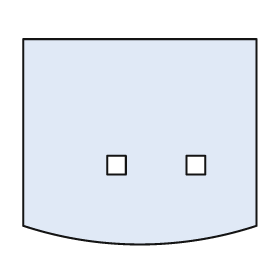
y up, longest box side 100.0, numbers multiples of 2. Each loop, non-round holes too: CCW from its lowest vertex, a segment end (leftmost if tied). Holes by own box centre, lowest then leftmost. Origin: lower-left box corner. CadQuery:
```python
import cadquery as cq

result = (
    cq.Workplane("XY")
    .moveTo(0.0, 8.0)
    .threePointArc((50.0, 0.0), (100.0, 8.0))
    .lineTo(100.0, 88.0)
    .lineTo(0.0, 88.0)
    .close()
    .moveTo(36.0, 30.0)
    .lineTo(44.0, 30.0)
    .lineTo(44.0, 38.0)
    .lineTo(36.0, 38.0)
    .close()
    .moveTo(70.0, 30.0)
    .lineTo(78.0, 30.0)
    .lineTo(78.0, 38.0)
    .lineTo(70.0, 38.0)
    .close()
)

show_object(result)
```